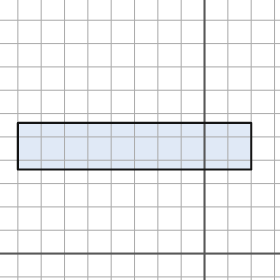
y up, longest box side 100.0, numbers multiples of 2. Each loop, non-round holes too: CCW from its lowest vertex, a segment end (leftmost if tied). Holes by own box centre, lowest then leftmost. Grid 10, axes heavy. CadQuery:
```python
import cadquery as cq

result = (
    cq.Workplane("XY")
    .moveTo(-80.0, 36.0)
    .lineTo(20.0, 36.0)
    .lineTo(20.0, 56.0)
    .lineTo(-80.0, 56.0)
    .close()
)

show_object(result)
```